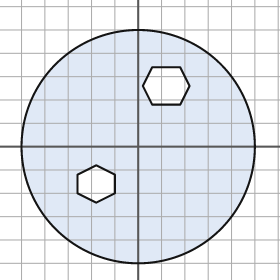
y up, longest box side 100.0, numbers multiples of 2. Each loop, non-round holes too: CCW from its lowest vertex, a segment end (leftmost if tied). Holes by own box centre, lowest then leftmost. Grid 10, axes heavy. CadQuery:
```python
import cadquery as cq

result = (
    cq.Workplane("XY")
    .moveTo(0.0, 0.0)
    .circle(50.0)
    .moveTo(-18.0, -24.0)
    .lineTo(-10.0, -20.0)
    .lineTo(-10.0, -12.0)
    .lineTo(-18.0, -8.0)
    .lineTo(-26.0, -12.0)
    .lineTo(-26.0, -20.0)
    .close()
    .moveTo(6.0, 18.0)
    .lineTo(18.0, 18.0)
    .lineTo(22.0, 26.0)
    .lineTo(18.0, 34.0)
    .lineTo(6.0, 34.0)
    .lineTo(2.0, 26.0)
    .close()
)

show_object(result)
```